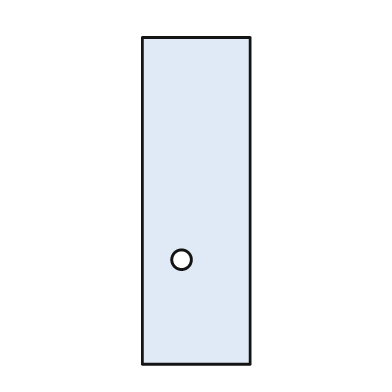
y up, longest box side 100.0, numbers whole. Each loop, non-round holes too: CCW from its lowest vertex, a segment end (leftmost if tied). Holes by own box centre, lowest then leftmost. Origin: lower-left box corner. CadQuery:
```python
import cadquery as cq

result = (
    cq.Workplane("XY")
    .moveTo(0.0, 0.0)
    .lineTo(33.0, 0.0)
    .lineTo(33.0, 100.0)
    .lineTo(0.0, 100.0)
    .close()
    .moveTo(12.0, 32.0)
    .circle(3.0)
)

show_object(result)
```